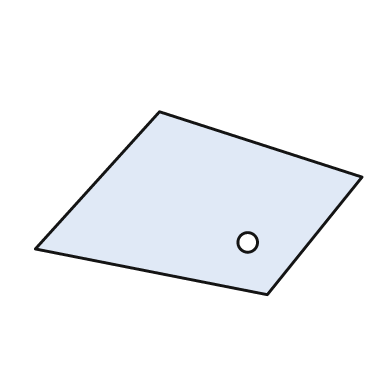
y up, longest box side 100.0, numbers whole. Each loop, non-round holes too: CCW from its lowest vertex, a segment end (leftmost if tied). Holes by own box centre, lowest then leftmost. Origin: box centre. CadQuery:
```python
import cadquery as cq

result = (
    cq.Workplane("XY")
    .moveTo(21.0, -28.0)
    .lineTo(50.0, 8.0)
    .lineTo(-12.0, 28.0)
    .lineTo(-50.0, -14.0)
    .close()
    .moveTo(15.0, -12.0)
    .circle(3.0)
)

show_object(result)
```